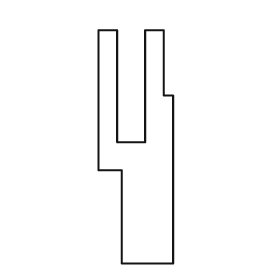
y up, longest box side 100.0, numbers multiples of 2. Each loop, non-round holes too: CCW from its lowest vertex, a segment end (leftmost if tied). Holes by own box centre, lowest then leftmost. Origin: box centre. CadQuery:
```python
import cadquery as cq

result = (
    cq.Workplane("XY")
    .moveTo(-6.0, -50.0)
    .lineTo(16.0, -50.0)
    .lineTo(16.0, 22.0)
    .lineTo(12.0, 22.0)
    .lineTo(12.0, 50.0)
    .lineTo(4.0, 50.0)
    .lineTo(4.0, 2.0)
    .lineTo(-8.0, 2.0)
    .lineTo(-8.0, 50.0)
    .lineTo(-16.0, 50.0)
    .lineTo(-16.0, -10.0)
    .lineTo(-6.0, -10.0)
    .close()
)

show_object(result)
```